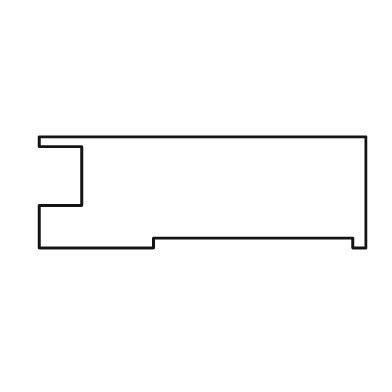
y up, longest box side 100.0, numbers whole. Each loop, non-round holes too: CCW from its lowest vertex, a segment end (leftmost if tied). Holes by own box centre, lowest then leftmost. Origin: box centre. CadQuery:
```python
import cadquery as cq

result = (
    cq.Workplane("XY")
    .moveTo(-50.0, -17.0)
    .lineTo(-15.0, -17.0)
    .lineTo(-15.0, -14.0)
    .lineTo(46.0, -14.0)
    .lineTo(46.0, -17.0)
    .lineTo(50.0, -17.0)
    .lineTo(50.0, 17.0)
    .lineTo(-50.0, 17.0)
    .lineTo(-50.0, 14.0)
    .lineTo(-37.0, 14.0)
    .lineTo(-37.0, -4.0)
    .lineTo(-50.0, -4.0)
    .close()
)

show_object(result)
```